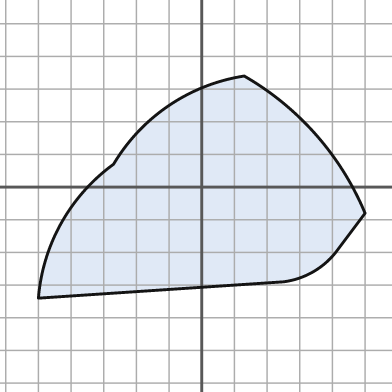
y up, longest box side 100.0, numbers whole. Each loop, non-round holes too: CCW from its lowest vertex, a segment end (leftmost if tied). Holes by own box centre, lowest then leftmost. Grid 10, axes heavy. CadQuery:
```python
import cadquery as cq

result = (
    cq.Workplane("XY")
    .moveTo(-50.0, -34.0)
    .lineTo(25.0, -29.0)
    .threePointArc((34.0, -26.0), (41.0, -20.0))
    .lineTo(50.0, -8.0)
    .threePointArc((35.0, 16.0), (13.0, 34.0))
    .threePointArc((-10.0, 25.0), (-27.0, 7.0))
    .threePointArc((-43.0, -11.0), (-50.0, -34.0))
    .close()
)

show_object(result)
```